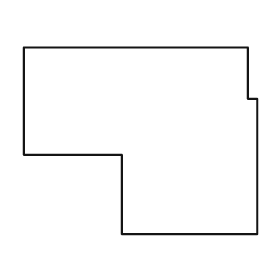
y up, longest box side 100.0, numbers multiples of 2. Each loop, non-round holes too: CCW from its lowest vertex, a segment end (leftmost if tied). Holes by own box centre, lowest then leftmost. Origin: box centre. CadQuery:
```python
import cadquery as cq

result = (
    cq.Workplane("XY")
    .moveTo(-8.0, -40.0)
    .lineTo(50.0, -40.0)
    .lineTo(50.0, 18.0)
    .lineTo(46.0, 18.0)
    .lineTo(46.0, 40.0)
    .lineTo(-50.0, 40.0)
    .lineTo(-50.0, -6.0)
    .lineTo(-8.0, -6.0)
    .close()
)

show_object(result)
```